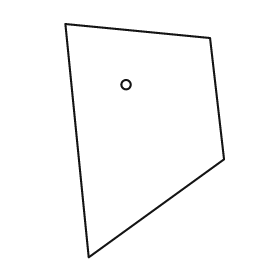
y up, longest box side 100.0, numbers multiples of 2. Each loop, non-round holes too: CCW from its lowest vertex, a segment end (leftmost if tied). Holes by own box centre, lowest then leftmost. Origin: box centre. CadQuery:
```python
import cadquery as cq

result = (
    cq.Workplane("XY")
    .moveTo(-24.0, -50.0)
    .lineTo(34.0, -8.0)
    .lineTo(28.0, 44.0)
    .lineTo(-34.0, 50.0)
    .close()
    .moveTo(-8.0, 24.0)
    .circle(2.0)
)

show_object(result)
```